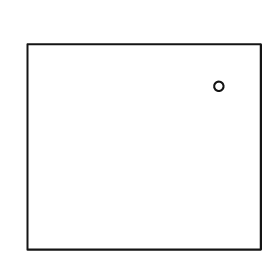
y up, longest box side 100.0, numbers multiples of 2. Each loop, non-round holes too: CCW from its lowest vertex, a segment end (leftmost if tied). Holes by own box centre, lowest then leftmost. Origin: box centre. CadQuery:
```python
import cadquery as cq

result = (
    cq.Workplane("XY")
    .moveTo(-50.0, -44.0)
    .lineTo(50.0, -44.0)
    .lineTo(50.0, 44.0)
    .lineTo(-50.0, 44.0)
    .close()
    .moveTo(32.0, 26.0)
    .circle(2.0)
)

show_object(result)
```